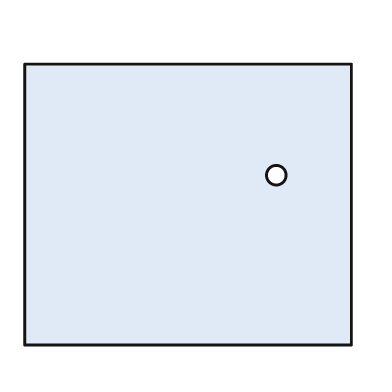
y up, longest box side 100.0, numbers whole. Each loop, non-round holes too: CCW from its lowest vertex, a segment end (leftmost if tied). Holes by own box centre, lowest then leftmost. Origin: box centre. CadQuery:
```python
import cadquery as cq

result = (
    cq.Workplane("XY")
    .moveTo(-50.0, -43.0)
    .lineTo(50.0, -43.0)
    .lineTo(50.0, 43.0)
    .lineTo(-50.0, 43.0)
    .close()
    .moveTo(27.0, 9.0)
    .circle(3.0)
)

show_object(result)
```